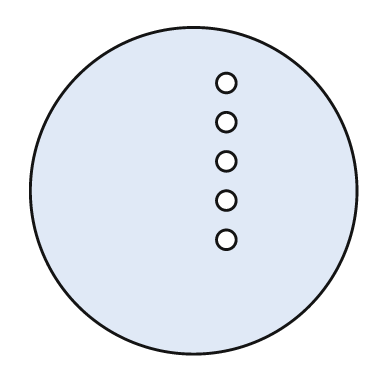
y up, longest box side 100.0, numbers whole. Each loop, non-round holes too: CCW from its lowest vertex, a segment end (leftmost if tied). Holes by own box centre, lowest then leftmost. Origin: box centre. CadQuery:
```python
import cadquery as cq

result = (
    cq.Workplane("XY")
    .moveTo(0.0, 0.0)
    .circle(50.0)
    .moveTo(10.0, -15.0)
    .circle(3.0)
    .moveTo(10.0, -3.0)
    .circle(3.0)
    .moveTo(10.0, 9.0)
    .circle(3.0)
    .moveTo(10.0, 21.0)
    .circle(3.0)
    .moveTo(10.0, 33.0)
    .circle(3.0)
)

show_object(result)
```